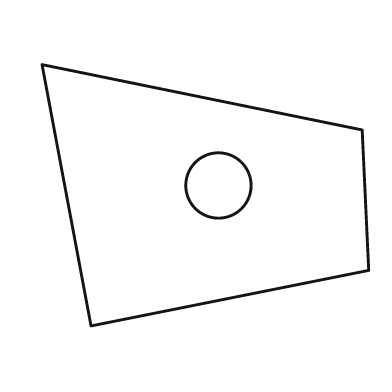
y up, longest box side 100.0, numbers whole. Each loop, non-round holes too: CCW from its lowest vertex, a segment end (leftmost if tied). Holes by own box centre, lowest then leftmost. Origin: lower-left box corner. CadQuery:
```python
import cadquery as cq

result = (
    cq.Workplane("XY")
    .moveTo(15.0, 0.0)
    .lineTo(100.0, 17.0)
    .lineTo(98.0, 60.0)
    .lineTo(0.0, 80.0)
    .close()
    .moveTo(54.0, 43.0)
    .circle(10.0)
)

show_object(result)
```